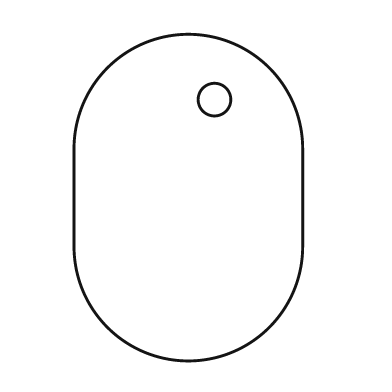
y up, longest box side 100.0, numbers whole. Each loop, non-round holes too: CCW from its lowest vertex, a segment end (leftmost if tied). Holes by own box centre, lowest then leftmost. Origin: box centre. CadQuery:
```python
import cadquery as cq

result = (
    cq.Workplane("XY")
    .moveTo(-35.0, -15.0)
    .threePointArc((0.0, -50.0), (35.0, -15.0))
    .lineTo(35.0, 15.0)
    .threePointArc((0.0, 50.0), (-35.0, 15.0))
    .close()
    .moveTo(8.0, 30.0)
    .circle(5.0)
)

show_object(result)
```